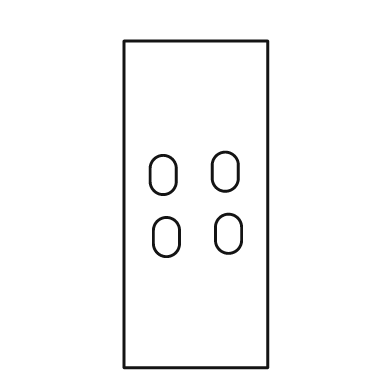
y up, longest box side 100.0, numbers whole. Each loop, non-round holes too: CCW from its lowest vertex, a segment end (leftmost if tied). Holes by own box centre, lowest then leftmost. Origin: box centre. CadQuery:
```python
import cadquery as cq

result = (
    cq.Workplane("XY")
    .moveTo(-22.0, -50.0)
    .lineTo(22.0, -50.0)
    .lineTo(22.0, 50.0)
    .lineTo(-22.0, 50.0)
    .close()
    .moveTo(-13.0, -12.0)
    .threePointArc((-9.0, -16.0), (-5.0, -12.0))
    .lineTo(-5.0, -8.0)
    .threePointArc((-9.0, -4.0), (-13.0, -8.0))
    .close()
    .moveTo(6.0, -11.0)
    .threePointArc((10.0, -15.0), (14.0, -11.0))
    .lineTo(14.0, -7.0)
    .threePointArc((10.0, -3.0), (6.0, -7.0))
    .close()
    .moveTo(-14.0, 7.0)
    .threePointArc((-10.0, 3.0), (-6.0, 7.0))
    .lineTo(-6.0, 11.0)
    .threePointArc((-10.0, 15.0), (-14.0, 11.0))
    .close()
    .moveTo(5.0, 8.0)
    .threePointArc((9.0, 4.0), (13.0, 8.0))
    .lineTo(13.0, 12.0)
    .threePointArc((9.0, 16.0), (5.0, 12.0))
    .close()
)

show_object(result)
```